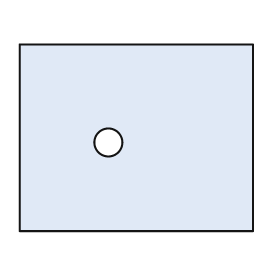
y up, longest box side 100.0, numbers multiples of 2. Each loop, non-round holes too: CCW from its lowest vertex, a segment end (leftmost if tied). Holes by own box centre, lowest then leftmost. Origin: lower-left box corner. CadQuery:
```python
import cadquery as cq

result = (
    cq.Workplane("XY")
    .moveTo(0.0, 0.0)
    .lineTo(100.0, 0.0)
    .lineTo(100.0, 80.0)
    .lineTo(0.0, 80.0)
    .close()
    .moveTo(38.0, 38.0)
    .circle(6.0)
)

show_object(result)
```